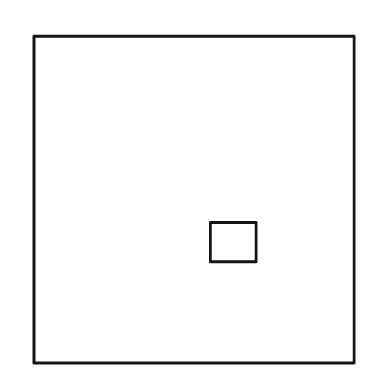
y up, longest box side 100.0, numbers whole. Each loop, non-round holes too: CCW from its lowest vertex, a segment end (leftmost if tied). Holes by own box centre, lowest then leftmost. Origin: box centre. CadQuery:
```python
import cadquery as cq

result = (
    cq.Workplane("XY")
    .moveTo(-49.0, -50.0)
    .lineTo(49.0, -50.0)
    .lineTo(49.0, 50.0)
    .lineTo(-49.0, 50.0)
    .close()
    .moveTo(5.0, -19.0)
    .lineTo(19.0, -19.0)
    .lineTo(19.0, -7.0)
    .lineTo(5.0, -7.0)
    .close()
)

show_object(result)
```